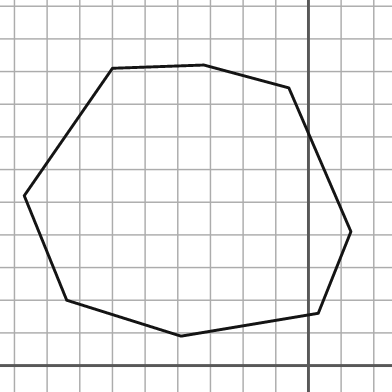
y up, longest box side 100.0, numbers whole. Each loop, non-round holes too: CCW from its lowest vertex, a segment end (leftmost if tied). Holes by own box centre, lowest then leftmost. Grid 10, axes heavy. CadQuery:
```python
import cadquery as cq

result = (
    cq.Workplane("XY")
    .moveTo(-39.0, 9.0)
    .lineTo(3.0, 16.0)
    .lineTo(13.0, 41.0)
    .lineTo(-6.0, 85.0)
    .lineTo(-32.0, 92.0)
    .lineTo(-60.0, 91.0)
    .lineTo(-87.0, 52.0)
    .lineTo(-74.0, 20.0)
    .close()
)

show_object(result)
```